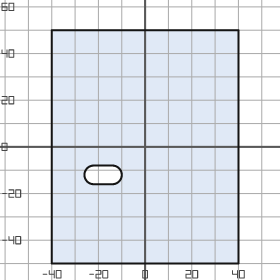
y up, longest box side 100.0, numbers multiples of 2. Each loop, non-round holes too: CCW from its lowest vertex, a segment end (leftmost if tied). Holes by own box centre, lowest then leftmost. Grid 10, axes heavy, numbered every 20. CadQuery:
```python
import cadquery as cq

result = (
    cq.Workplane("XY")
    .moveTo(-40.0, -50.0)
    .lineTo(40.0, -50.0)
    .lineTo(40.0, 50.0)
    .lineTo(-40.0, 50.0)
    .close()
    .moveTo(-22.0, -16.0)
    .lineTo(-14.0, -16.0)
    .threePointArc((-10.0, -12.0), (-14.0, -8.0))
    .lineTo(-22.0, -8.0)
    .threePointArc((-26.0, -12.0), (-22.0, -16.0))
    .close()
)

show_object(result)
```